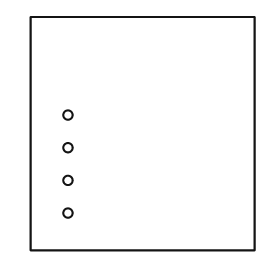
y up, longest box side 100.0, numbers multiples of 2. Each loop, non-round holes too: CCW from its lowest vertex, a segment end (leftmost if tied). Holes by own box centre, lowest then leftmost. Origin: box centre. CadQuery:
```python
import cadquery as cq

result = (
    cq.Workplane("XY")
    .moveTo(-48.0, -50.0)
    .lineTo(48.0, -50.0)
    .lineTo(48.0, 50.0)
    .lineTo(-48.0, 50.0)
    .close()
    .moveTo(-32.0, -34.0)
    .circle(2.0)
    .moveTo(-32.0, -20.0)
    .circle(2.0)
    .moveTo(-32.0, -6.0)
    .circle(2.0)
    .moveTo(-32.0, 8.0)
    .circle(2.0)
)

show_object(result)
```